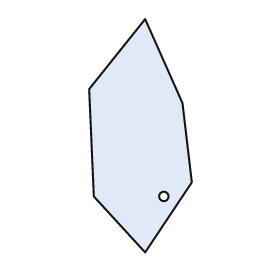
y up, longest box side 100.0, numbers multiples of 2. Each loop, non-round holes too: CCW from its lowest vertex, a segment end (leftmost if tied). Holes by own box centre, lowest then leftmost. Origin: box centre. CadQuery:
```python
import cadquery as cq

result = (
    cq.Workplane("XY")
    .moveTo(2.0, -50.0)
    .lineTo(22.0, -20.0)
    .lineTo(18.0, 14.0)
    .lineTo(2.0, 50.0)
    .lineTo(-22.0, 20.0)
    .lineTo(-20.0, -26.0)
    .close()
    .moveTo(10.0, -26.0)
    .circle(2.0)
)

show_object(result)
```